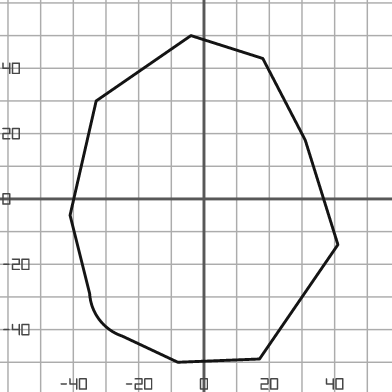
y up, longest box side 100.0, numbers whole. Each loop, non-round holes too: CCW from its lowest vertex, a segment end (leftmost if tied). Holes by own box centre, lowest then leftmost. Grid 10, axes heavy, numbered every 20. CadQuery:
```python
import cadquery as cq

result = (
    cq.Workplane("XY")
    .moveTo(-8.0, -50.0)
    .lineTo(17.0, -49.0)
    .lineTo(41.0, -14.0)
    .lineTo(31.0, 18.0)
    .lineTo(18.0, 43.0)
    .lineTo(-4.0, 50.0)
    .lineTo(-33.0, 30.0)
    .lineTo(-41.0, -5.0)
    .lineTo(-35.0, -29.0)
    .threePointArc((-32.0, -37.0), (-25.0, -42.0))
    .close()
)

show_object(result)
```